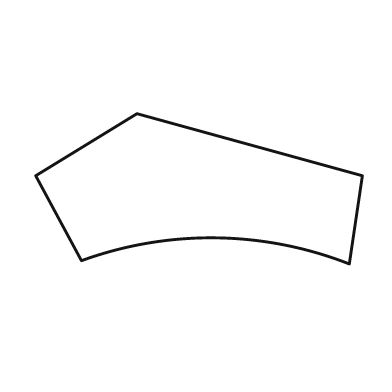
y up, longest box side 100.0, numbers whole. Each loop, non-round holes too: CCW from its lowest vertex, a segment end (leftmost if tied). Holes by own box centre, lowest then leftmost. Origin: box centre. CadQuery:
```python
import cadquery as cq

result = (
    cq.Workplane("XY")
    .moveTo(46.0, -23.0)
    .lineTo(50.0, 4.0)
    .lineTo(-19.0, 23.0)
    .lineTo(-50.0, 4.0)
    .lineTo(-36.0, -22.0)
    .threePointArc((5.0, -15.0), (46.0, -23.0))
    .close()
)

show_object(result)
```